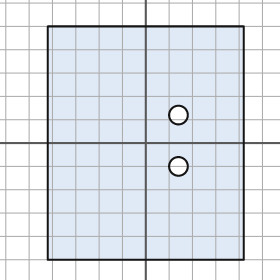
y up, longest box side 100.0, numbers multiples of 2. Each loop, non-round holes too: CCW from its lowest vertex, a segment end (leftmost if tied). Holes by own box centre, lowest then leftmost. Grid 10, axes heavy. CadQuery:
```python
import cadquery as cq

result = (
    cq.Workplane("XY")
    .moveTo(-42.0, -50.0)
    .lineTo(42.0, -50.0)
    .lineTo(42.0, 50.0)
    .lineTo(-42.0, 50.0)
    .close()
    .moveTo(14.0, -10.0)
    .circle(4.0)
    .moveTo(14.0, 12.0)
    .circle(4.0)
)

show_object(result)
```